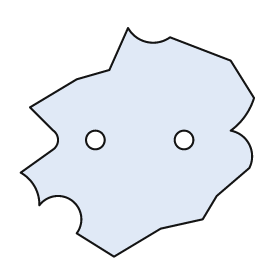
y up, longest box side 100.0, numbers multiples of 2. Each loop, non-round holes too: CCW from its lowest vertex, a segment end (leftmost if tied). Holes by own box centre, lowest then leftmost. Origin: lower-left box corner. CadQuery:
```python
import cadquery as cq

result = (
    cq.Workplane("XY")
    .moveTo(40.0, 0.0)
    .lineTo(60.0, 12.0)
    .lineTo(78.0, 16.0)
    .lineTo(84.0, 26.0)
    .lineTo(98.0, 38.0)
    .threePointArc((98.0, 48.0), (90.0, 54.0))
    .threePointArc((96.0, 60.0), (100.0, 68.0))
    .lineTo(90.0, 84.0)
    .lineTo(64.0, 94.0)
    .threePointArc((54.0, 92.0), (46.0, 98.0))
    .lineTo(38.0, 80.0)
    .lineTo(24.0, 76.0)
    .lineTo(4.0, 64.0)
    .lineTo(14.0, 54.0)
    .threePointArc((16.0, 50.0), (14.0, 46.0))
    .lineTo(0.0, 36.0)
    .threePointArc((6.0, 30.0), (8.0, 22.0))
    .threePointArc((22.0, 24.0), (24.0, 10.0))
    .close()
    .moveTo(32.0, 50.0)
    .circle(4.0)
    .moveTo(70.0, 50.0)
    .circle(4.0)
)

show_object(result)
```